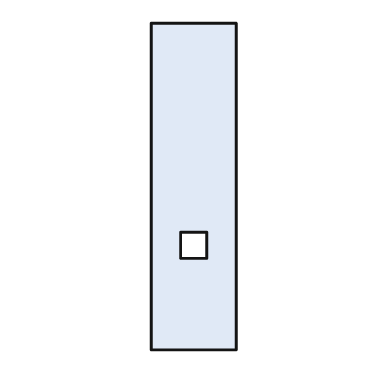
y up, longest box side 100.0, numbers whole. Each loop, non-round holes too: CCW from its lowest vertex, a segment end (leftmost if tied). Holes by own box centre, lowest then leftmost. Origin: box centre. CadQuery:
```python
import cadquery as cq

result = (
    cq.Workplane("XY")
    .moveTo(-13.0, -50.0)
    .lineTo(13.0, -50.0)
    .lineTo(13.0, 50.0)
    .lineTo(-13.0, 50.0)
    .close()
    .moveTo(-4.0, -22.0)
    .lineTo(4.0, -22.0)
    .lineTo(4.0, -14.0)
    .lineTo(-4.0, -14.0)
    .close()
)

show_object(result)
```